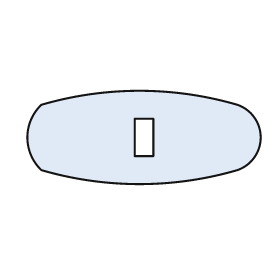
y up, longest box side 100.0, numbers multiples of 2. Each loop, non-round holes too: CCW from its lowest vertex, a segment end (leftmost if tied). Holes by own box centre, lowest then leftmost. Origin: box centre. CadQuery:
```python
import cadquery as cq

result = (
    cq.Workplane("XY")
    .moveTo(-44.0, -14.0)
    .threePointArc((-2.0, -20.0), (40.0, -14.0))
    .threePointArc((50.0, 0.0), (40.0, 14.0))
    .threePointArc((-2.0, 20.0), (-44.0, 14.0))
    .threePointArc((-50.0, 0.0), (-44.0, -14.0))
    .close()
    .moveTo(-4.0, -8.0)
    .lineTo(4.0, -8.0)
    .lineTo(4.0, 8.0)
    .lineTo(-4.0, 8.0)
    .close()
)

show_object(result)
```